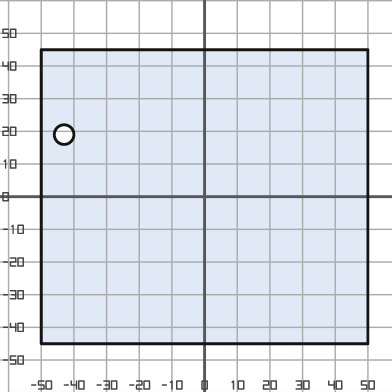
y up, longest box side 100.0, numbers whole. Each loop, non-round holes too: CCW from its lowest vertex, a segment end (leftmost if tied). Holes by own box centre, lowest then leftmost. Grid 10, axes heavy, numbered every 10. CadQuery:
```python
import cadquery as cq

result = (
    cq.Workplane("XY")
    .moveTo(-50.0, -45.0)
    .lineTo(50.0, -45.0)
    .lineTo(50.0, 45.0)
    .lineTo(-50.0, 45.0)
    .close()
    .moveTo(-43.0, 19.0)
    .circle(3.0)
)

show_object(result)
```